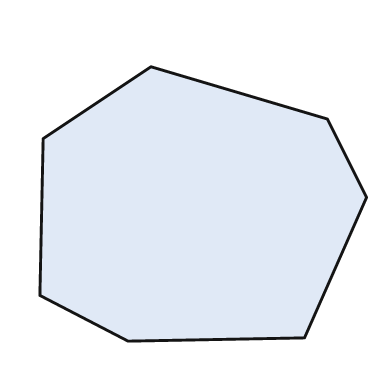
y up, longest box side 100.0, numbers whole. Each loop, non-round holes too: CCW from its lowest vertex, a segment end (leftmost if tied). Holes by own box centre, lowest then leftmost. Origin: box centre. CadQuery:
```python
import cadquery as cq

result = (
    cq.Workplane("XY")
    .moveTo(-23.0, -42.0)
    .lineTo(31.0, -41.0)
    .lineTo(50.0, 2.0)
    .lineTo(38.0, 26.0)
    .lineTo(-16.0, 42.0)
    .lineTo(-49.0, 20.0)
    .lineTo(-50.0, -28.0)
    .close()
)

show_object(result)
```